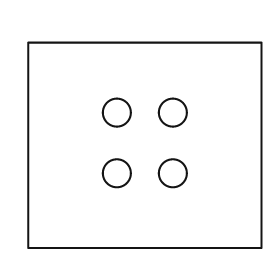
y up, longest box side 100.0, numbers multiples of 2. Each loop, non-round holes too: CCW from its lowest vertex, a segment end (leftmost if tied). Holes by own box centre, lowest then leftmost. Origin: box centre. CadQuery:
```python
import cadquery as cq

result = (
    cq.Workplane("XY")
    .moveTo(-50.0, -44.0)
    .lineTo(50.0, -44.0)
    .lineTo(50.0, 44.0)
    .lineTo(-50.0, 44.0)
    .close()
    .moveTo(-12.0, -12.0)
    .circle(6.0)
    .moveTo(12.0, -12.0)
    .circle(6.0)
    .moveTo(-12.0, 14.0)
    .circle(6.0)
    .moveTo(12.0, 14.0)
    .circle(6.0)
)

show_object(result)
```